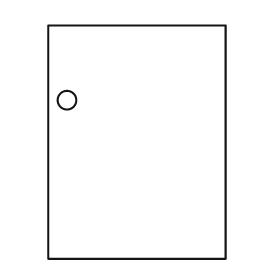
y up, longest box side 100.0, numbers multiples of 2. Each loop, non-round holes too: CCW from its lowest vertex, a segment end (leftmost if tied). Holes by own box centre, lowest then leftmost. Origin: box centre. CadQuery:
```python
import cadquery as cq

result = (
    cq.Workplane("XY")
    .moveTo(-38.0, -50.0)
    .lineTo(38.0, -50.0)
    .lineTo(38.0, 50.0)
    .lineTo(-38.0, 50.0)
    .close()
    .moveTo(-30.0, 18.0)
    .circle(4.0)
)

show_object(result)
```